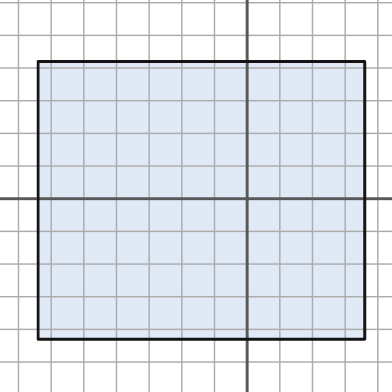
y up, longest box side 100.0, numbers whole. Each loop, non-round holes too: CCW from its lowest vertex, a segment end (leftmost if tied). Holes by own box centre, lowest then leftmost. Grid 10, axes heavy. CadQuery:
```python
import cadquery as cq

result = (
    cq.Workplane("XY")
    .moveTo(-64.0, -43.0)
    .lineTo(36.0, -43.0)
    .lineTo(36.0, 42.0)
    .lineTo(-64.0, 42.0)
    .close()
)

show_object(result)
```